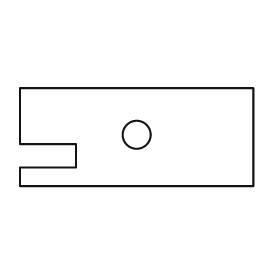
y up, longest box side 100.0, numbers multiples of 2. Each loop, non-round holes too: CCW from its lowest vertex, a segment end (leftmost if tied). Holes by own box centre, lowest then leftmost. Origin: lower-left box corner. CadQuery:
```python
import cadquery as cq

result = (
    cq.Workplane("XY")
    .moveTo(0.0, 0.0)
    .lineTo(100.0, 0.0)
    .lineTo(100.0, 42.0)
    .lineTo(0.0, 42.0)
    .lineTo(0.0, 18.0)
    .lineTo(24.0, 18.0)
    .lineTo(24.0, 8.0)
    .lineTo(0.0, 8.0)
    .close()
    .moveTo(50.0, 22.0)
    .circle(6.0)
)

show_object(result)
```